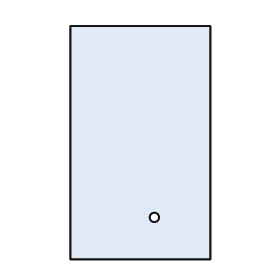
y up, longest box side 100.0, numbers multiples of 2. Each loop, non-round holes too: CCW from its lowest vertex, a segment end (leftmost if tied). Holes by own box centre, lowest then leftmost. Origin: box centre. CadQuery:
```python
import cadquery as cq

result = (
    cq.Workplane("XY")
    .moveTo(-30.0, -50.0)
    .lineTo(30.0, -50.0)
    .lineTo(30.0, 50.0)
    .lineTo(-30.0, 50.0)
    .close()
    .moveTo(6.0, -32.0)
    .circle(2.0)
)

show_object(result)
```